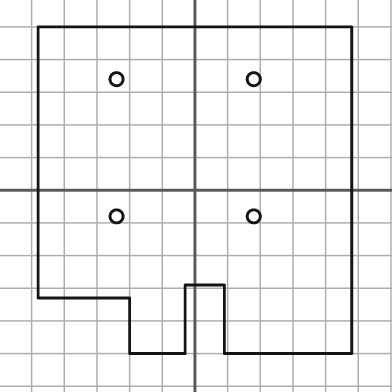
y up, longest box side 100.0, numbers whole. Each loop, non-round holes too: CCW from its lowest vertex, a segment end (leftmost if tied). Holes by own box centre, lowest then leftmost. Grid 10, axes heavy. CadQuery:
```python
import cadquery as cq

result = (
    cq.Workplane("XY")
    .moveTo(-20.0, -50.0)
    .lineTo(-3.0, -50.0)
    .lineTo(-3.0, -29.0)
    .lineTo(9.0, -29.0)
    .lineTo(9.0, -50.0)
    .lineTo(48.0, -50.0)
    .lineTo(48.0, 50.0)
    .lineTo(-48.0, 50.0)
    .lineTo(-48.0, -33.0)
    .lineTo(-20.0, -33.0)
    .close()
    .moveTo(-24.0, -8.0)
    .circle(2.0)
    .moveTo(18.0, -8.0)
    .circle(2.0)
    .moveTo(-24.0, 34.0)
    .circle(2.0)
    .moveTo(18.0, 34.0)
    .circle(2.0)
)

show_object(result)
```